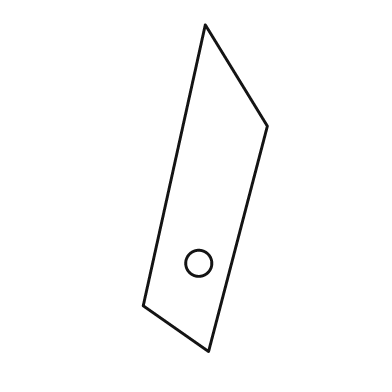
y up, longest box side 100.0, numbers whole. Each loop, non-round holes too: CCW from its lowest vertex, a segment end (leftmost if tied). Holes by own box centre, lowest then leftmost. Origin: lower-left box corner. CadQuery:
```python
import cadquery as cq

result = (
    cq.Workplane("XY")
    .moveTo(20.0, 0.0)
    .lineTo(38.0, 69.0)
    .lineTo(19.0, 100.0)
    .lineTo(0.0, 14.0)
    .close()
    .moveTo(17.0, 27.0)
    .circle(4.0)
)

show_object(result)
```